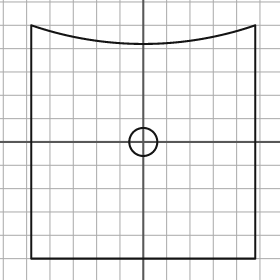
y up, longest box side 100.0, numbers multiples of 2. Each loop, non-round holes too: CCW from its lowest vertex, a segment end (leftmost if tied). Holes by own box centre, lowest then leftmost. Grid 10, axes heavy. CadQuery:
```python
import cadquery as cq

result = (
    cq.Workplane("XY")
    .moveTo(-48.0, -50.0)
    .lineTo(48.0, -50.0)
    .lineTo(48.0, 50.0)
    .threePointArc((0.0, 42.0), (-48.0, 50.0))
    .close()
    .moveTo(0.0, 0.0)
    .circle(6.0)
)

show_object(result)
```